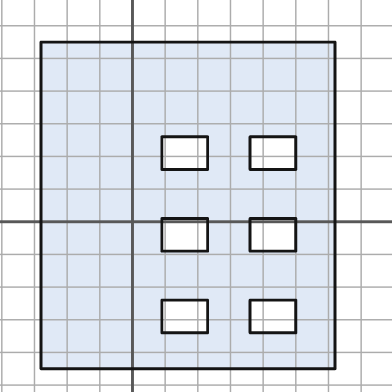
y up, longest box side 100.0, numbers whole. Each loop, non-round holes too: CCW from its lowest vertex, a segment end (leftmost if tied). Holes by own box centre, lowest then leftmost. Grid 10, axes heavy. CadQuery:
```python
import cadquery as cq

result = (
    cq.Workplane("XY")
    .moveTo(-28.0, -45.0)
    .lineTo(62.0, -45.0)
    .lineTo(62.0, 55.0)
    .lineTo(-28.0, 55.0)
    .close()
    .moveTo(9.0, -34.0)
    .lineTo(23.0, -34.0)
    .lineTo(23.0, -24.0)
    .lineTo(9.0, -24.0)
    .close()
    .moveTo(36.0, -34.0)
    .lineTo(50.0, -34.0)
    .lineTo(50.0, -24.0)
    .lineTo(36.0, -24.0)
    .close()
    .moveTo(9.0, -9.0)
    .lineTo(23.0, -9.0)
    .lineTo(23.0, 1.0)
    .lineTo(9.0, 1.0)
    .close()
    .moveTo(36.0, -9.0)
    .lineTo(50.0, -9.0)
    .lineTo(50.0, 1.0)
    .lineTo(36.0, 1.0)
    .close()
    .moveTo(9.0, 16.0)
    .lineTo(23.0, 16.0)
    .lineTo(23.0, 26.0)
    .lineTo(9.0, 26.0)
    .close()
    .moveTo(36.0, 16.0)
    .lineTo(50.0, 16.0)
    .lineTo(50.0, 26.0)
    .lineTo(36.0, 26.0)
    .close()
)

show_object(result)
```